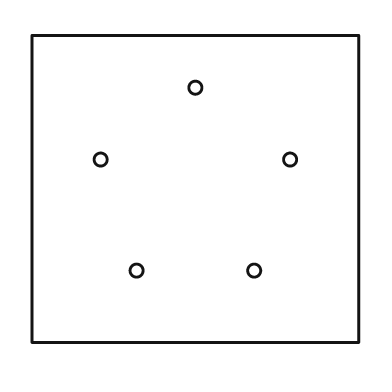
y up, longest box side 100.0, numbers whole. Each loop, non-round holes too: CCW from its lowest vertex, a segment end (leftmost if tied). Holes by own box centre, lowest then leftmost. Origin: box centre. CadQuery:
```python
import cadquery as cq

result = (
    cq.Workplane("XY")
    .moveTo(-50.0, -47.0)
    .lineTo(50.0, -47.0)
    .lineTo(50.0, 47.0)
    .lineTo(-50.0, 47.0)
    .close()
    .moveTo(-18.0, -25.0)
    .circle(2.0)
    .moveTo(18.0, -25.0)
    .circle(2.0)
    .moveTo(-29.0, 9.0)
    .circle(2.0)
    .moveTo(29.0, 9.0)
    .circle(2.0)
    .moveTo(0.0, 31.0)
    .circle(2.0)
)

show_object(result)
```